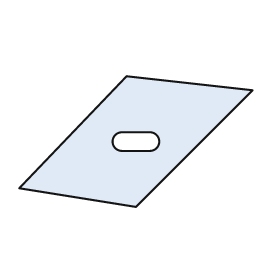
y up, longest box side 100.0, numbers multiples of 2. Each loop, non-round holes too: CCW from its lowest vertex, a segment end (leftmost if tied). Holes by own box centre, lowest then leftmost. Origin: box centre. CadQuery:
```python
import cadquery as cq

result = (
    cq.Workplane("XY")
    .moveTo(0.0, -28.0)
    .lineTo(50.0, 22.0)
    .lineTo(-4.0, 28.0)
    .lineTo(-50.0, -20.0)
    .close()
    .moveTo(-6.0, -4.0)
    .lineTo(6.0, -4.0)
    .threePointArc((10.0, 0.0), (6.0, 4.0))
    .lineTo(-6.0, 4.0)
    .threePointArc((-10.0, 0.0), (-6.0, -4.0))
    .close()
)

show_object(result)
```